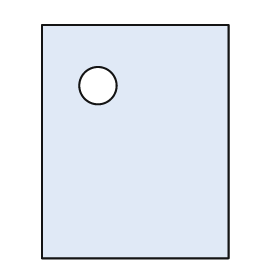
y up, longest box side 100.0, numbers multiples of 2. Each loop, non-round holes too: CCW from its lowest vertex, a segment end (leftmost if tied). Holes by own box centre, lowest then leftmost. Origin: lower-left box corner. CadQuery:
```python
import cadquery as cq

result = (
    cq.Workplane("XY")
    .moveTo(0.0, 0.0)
    .lineTo(80.0, 0.0)
    .lineTo(80.0, 100.0)
    .lineTo(0.0, 100.0)
    .close()
    .moveTo(24.0, 74.0)
    .circle(8.0)
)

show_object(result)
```